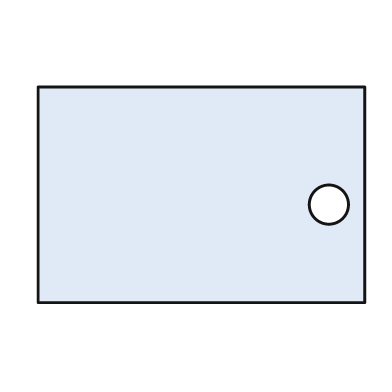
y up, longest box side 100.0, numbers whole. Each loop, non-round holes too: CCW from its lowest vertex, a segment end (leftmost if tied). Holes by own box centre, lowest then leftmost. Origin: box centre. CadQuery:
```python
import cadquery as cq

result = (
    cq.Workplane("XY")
    .moveTo(-50.0, -33.0)
    .lineTo(50.0, -33.0)
    .lineTo(50.0, 33.0)
    .lineTo(-50.0, 33.0)
    .close()
    .moveTo(39.0, -3.0)
    .circle(6.0)
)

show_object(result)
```